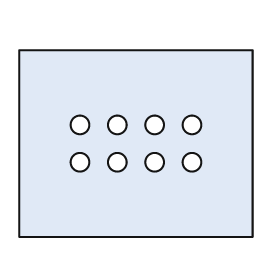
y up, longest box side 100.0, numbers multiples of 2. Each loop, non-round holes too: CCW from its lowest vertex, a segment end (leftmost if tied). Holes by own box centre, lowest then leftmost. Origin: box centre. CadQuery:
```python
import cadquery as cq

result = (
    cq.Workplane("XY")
    .moveTo(-50.0, -40.0)
    .lineTo(50.0, -40.0)
    .lineTo(50.0, 40.0)
    .lineTo(-50.0, 40.0)
    .close()
    .moveTo(-24.0, -8.0)
    .circle(4.0)
    .moveTo(-8.0, -8.0)
    .circle(4.0)
    .moveTo(8.0, -8.0)
    .circle(4.0)
    .moveTo(24.0, -8.0)
    .circle(4.0)
    .moveTo(-24.0, 8.0)
    .circle(4.0)
    .moveTo(-8.0, 8.0)
    .circle(4.0)
    .moveTo(8.0, 8.0)
    .circle(4.0)
    .moveTo(24.0, 8.0)
    .circle(4.0)
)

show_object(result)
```